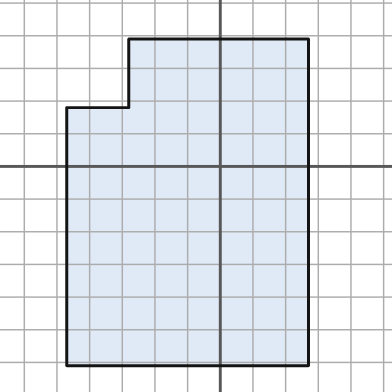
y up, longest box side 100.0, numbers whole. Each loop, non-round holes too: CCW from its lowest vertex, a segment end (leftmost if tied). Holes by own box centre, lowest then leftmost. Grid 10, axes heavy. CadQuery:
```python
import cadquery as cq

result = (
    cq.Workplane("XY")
    .moveTo(-47.0, -61.0)
    .lineTo(27.0, -61.0)
    .lineTo(27.0, 39.0)
    .lineTo(-28.0, 39.0)
    .lineTo(-28.0, 18.0)
    .lineTo(-47.0, 18.0)
    .close()
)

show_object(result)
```